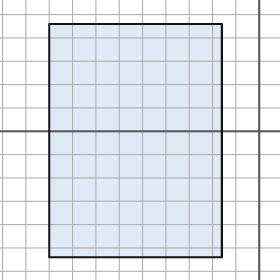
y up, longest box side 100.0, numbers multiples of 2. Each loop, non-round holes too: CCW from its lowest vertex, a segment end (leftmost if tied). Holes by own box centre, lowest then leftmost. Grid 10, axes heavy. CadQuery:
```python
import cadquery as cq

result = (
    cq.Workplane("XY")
    .moveTo(-90.0, -54.0)
    .lineTo(-16.0, -54.0)
    .lineTo(-16.0, 46.0)
    .lineTo(-90.0, 46.0)
    .close()
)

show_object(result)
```